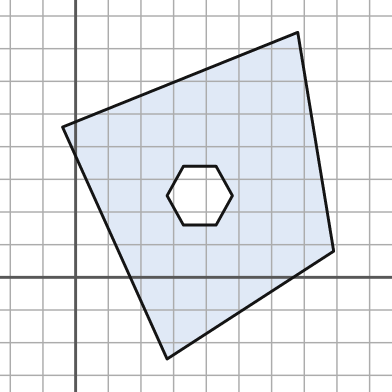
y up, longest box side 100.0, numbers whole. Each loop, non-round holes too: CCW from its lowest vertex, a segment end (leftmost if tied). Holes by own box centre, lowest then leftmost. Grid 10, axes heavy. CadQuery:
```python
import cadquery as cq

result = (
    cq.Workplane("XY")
    .moveTo(28.0, -25.0)
    .lineTo(79.0, 8.0)
    .lineTo(68.0, 75.0)
    .lineTo(-4.0, 46.0)
    .close()
    .moveTo(33.0, 16.0)
    .lineTo(43.0, 16.0)
    .lineTo(48.0, 25.0)
    .lineTo(43.0, 34.0)
    .lineTo(33.0, 34.0)
    .lineTo(28.0, 25.0)
    .close()
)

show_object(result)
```